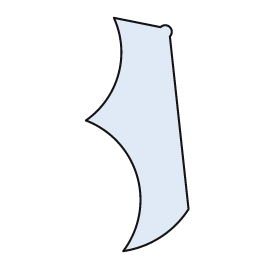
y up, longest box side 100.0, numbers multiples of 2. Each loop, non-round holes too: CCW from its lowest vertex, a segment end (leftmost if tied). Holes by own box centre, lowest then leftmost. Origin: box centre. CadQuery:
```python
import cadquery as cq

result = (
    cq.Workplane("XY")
    .moveTo(-6.0, -50.0)
    .threePointArc((10.0, -44.0), (22.0, -32.0))
    .lineTo(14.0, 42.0)
    .threePointArc((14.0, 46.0), (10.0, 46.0))
    .lineTo(-10.0, 50.0)
    .threePointArc((-8.0, 26.0), (-22.0, 6.0))
    .threePointArc((0.0, -18.0), (-6.0, -50.0))
    .close()
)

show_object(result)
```